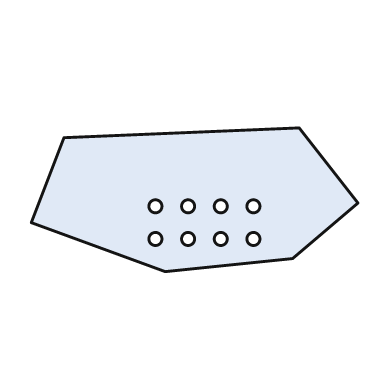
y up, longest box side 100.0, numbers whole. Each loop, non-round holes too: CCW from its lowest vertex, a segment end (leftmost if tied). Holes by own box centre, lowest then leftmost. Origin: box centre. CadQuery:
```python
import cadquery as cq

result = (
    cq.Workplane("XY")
    .moveTo(-9.0, -22.0)
    .lineTo(30.0, -18.0)
    .lineTo(50.0, -1.0)
    .lineTo(32.0, 22.0)
    .lineTo(-40.0, 19.0)
    .lineTo(-50.0, -7.0)
    .close()
    .moveTo(-12.0, -12.0)
    .circle(2.0)
    .moveTo(-2.0, -12.0)
    .circle(2.0)
    .moveTo(8.0, -12.0)
    .circle(2.0)
    .moveTo(18.0, -12.0)
    .circle(2.0)
    .moveTo(-12.0, -2.0)
    .circle(2.0)
    .moveTo(-2.0, -2.0)
    .circle(2.0)
    .moveTo(8.0, -2.0)
    .circle(2.0)
    .moveTo(18.0, -2.0)
    .circle(2.0)
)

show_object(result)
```